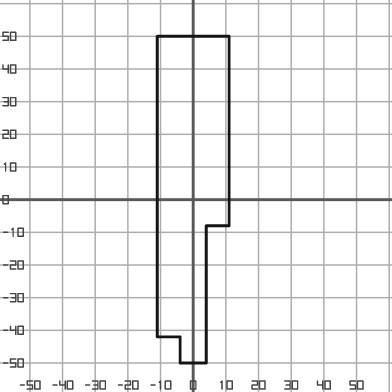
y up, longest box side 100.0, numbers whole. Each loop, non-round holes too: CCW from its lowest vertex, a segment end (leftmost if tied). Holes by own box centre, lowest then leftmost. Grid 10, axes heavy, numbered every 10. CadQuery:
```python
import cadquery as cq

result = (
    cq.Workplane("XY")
    .moveTo(-4.0, -50.0)
    .lineTo(4.0, -50.0)
    .lineTo(4.0, -8.0)
    .lineTo(11.0, -8.0)
    .lineTo(11.0, 50.0)
    .lineTo(-11.0, 50.0)
    .lineTo(-11.0, -42.0)
    .lineTo(-4.0, -42.0)
    .close()
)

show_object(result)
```